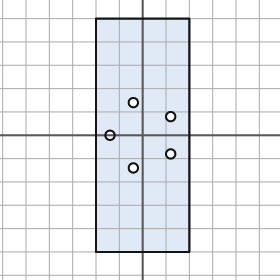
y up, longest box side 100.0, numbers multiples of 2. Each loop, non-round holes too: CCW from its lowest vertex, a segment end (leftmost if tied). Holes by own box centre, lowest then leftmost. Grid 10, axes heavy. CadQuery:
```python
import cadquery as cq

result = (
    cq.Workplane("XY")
    .moveTo(-20.0, -50.0)
    .lineTo(20.0, -50.0)
    .lineTo(20.0, 50.0)
    .lineTo(-20.0, 50.0)
    .close()
    .moveTo(-4.0, -14.0)
    .circle(2.0)
    .moveTo(12.0, -8.0)
    .circle(2.0)
    .moveTo(-14.0, 0.0)
    .circle(2.0)
    .moveTo(12.0, 8.0)
    .circle(2.0)
    .moveTo(-4.0, 14.0)
    .circle(2.0)
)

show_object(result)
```